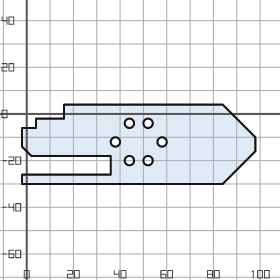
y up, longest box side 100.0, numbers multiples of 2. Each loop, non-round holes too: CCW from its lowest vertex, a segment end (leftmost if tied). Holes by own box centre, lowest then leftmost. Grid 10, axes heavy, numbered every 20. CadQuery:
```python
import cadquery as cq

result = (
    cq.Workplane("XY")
    .moveTo(-2.0, -30.0)
    .lineTo(84.0, -30.0)
    .lineTo(98.0, -16.0)
    .lineTo(98.0, -10.0)
    .lineTo(84.0, 4.0)
    .lineTo(16.0, 4.0)
    .lineTo(16.0, -2.0)
    .lineTo(4.0, -2.0)
    .lineTo(4.0, -6.0)
    .lineTo(-2.0, -6.0)
    .lineTo(-2.0, -14.0)
    .lineTo(2.0, -18.0)
    .lineTo(36.0, -18.0)
    .lineTo(36.0, -26.0)
    .lineTo(-2.0, -26.0)
    .close()
    .moveTo(44.0, -20.0)
    .circle(2.0)
    .moveTo(52.0, -20.0)
    .circle(2.0)
    .moveTo(38.0, -12.0)
    .circle(2.0)
    .moveTo(58.0, -12.0)
    .circle(2.0)
    .moveTo(44.0, -4.0)
    .circle(2.0)
    .moveTo(52.0, -4.0)
    .circle(2.0)
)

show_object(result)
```